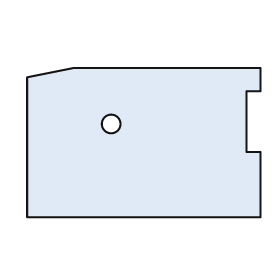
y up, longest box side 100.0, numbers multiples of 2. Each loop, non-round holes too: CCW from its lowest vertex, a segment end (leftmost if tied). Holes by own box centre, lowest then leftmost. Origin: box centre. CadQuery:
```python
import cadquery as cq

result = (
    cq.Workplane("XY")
    .moveTo(-50.0, -32.0)
    .lineTo(50.0, -32.0)
    .lineTo(50.0, -4.0)
    .lineTo(44.0, -4.0)
    .lineTo(44.0, 22.0)
    .lineTo(50.0, 22.0)
    .lineTo(50.0, 32.0)
    .lineTo(-30.0, 32.0)
    .lineTo(-50.0, 28.0)
    .close()
    .moveTo(-14.0, 8.0)
    .circle(4.0)
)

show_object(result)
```